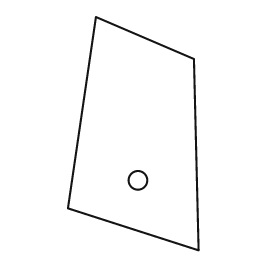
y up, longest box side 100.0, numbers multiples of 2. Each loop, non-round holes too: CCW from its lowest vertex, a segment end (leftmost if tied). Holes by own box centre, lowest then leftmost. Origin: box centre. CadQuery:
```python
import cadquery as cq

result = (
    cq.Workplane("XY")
    .moveTo(28.0, -50.0)
    .lineTo(26.0, 32.0)
    .lineTo(-16.0, 50.0)
    .lineTo(-28.0, -32.0)
    .close()
    .moveTo(2.0, -20.0)
    .circle(4.0)
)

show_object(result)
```